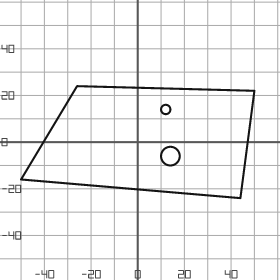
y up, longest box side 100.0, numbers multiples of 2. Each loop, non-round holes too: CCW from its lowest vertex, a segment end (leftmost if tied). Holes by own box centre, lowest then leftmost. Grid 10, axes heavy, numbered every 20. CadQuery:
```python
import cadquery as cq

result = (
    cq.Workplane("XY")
    .moveTo(44.0, -24.0)
    .lineTo(50.0, 22.0)
    .lineTo(-26.0, 24.0)
    .lineTo(-50.0, -16.0)
    .close()
    .moveTo(14.0, -6.0)
    .circle(4.0)
    .moveTo(12.0, 14.0)
    .circle(2.0)
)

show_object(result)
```